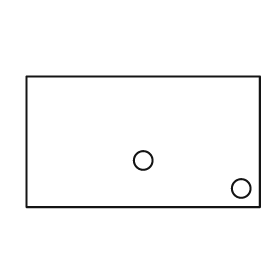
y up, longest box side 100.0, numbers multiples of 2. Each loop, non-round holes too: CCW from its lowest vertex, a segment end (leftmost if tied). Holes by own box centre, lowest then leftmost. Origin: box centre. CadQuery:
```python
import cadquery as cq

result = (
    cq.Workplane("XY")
    .moveTo(-50.0, -28.0)
    .lineTo(50.0, -28.0)
    .lineTo(50.0, 28.0)
    .lineTo(-50.0, 28.0)
    .close()
    .moveTo(42.0, -20.0)
    .circle(4.0)
    .moveTo(0.0, -8.0)
    .circle(4.0)
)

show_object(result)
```